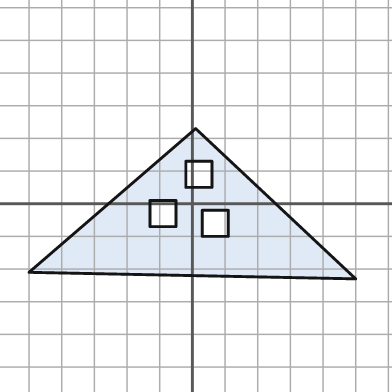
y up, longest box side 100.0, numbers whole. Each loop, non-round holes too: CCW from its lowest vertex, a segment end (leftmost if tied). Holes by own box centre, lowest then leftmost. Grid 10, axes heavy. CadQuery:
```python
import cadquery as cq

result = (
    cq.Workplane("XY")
    .moveTo(50.0, -23.0)
    .lineTo(1.0, 23.0)
    .lineTo(-50.0, -21.0)
    .close()
    .moveTo(3.0, -10.0)
    .lineTo(11.0, -10.0)
    .lineTo(11.0, -2.0)
    .lineTo(3.0, -2.0)
    .close()
    .moveTo(-13.0, -7.0)
    .lineTo(-5.0, -7.0)
    .lineTo(-5.0, 1.0)
    .lineTo(-13.0, 1.0)
    .close()
    .moveTo(-2.0, 5.0)
    .lineTo(6.0, 5.0)
    .lineTo(6.0, 13.0)
    .lineTo(-2.0, 13.0)
    .close()
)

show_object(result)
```